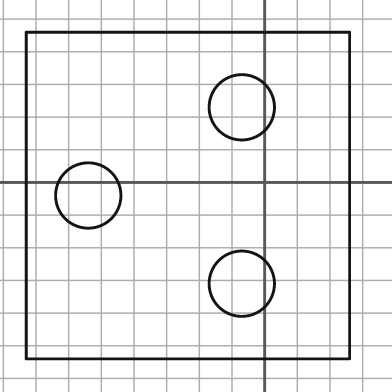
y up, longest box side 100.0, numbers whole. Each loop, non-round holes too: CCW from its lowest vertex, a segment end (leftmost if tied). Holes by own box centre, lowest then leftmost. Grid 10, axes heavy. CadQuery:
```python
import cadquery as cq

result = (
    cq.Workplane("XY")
    .moveTo(-73.0, -54.0)
    .lineTo(26.0, -54.0)
    .lineTo(26.0, 46.0)
    .lineTo(-73.0, 46.0)
    .close()
    .moveTo(-7.0, -31.0)
    .circle(10.0)
    .moveTo(-54.0, -4.0)
    .circle(10.0)
    .moveTo(-7.0, 23.0)
    .circle(10.0)
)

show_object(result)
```